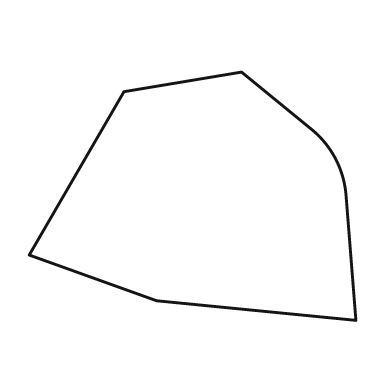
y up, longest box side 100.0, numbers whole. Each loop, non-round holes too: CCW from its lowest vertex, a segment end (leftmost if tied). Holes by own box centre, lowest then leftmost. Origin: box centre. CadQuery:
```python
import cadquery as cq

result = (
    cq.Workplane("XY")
    .moveTo(50.0, -38.0)
    .lineTo(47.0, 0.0)
    .threePointArc((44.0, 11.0), (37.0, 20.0))
    .lineTo(15.0, 38.0)
    .lineTo(-21.0, 32.0)
    .lineTo(-50.0, -18.0)
    .lineTo(-11.0, -32.0)
    .close()
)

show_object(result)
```